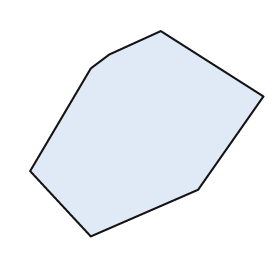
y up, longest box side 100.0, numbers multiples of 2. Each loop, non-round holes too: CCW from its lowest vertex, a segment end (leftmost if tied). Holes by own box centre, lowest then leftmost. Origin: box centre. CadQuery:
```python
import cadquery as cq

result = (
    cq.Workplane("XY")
    .moveTo(-24.0, -44.0)
    .lineTo(22.0, -24.0)
    .lineTo(50.0, 16.0)
    .lineTo(6.0, 44.0)
    .lineTo(-16.0, 34.0)
    .lineTo(-24.0, 28.0)
    .lineTo(-50.0, -16.0)
    .close()
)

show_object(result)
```